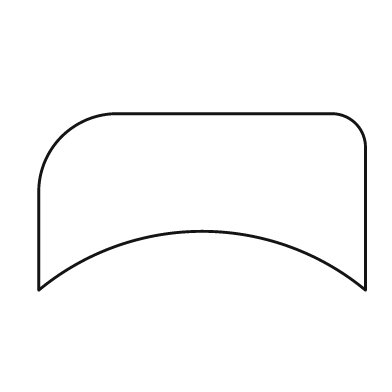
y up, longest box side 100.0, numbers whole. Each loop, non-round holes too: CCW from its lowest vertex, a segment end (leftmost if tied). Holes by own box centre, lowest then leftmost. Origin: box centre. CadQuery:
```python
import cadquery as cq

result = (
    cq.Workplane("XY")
    .moveTo(-50.0, -27.0)
    .threePointArc((0.0, -9.0), (50.0, -27.0))
    .lineTo(50.0, 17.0)
    .threePointArc((47.0, 24.0), (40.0, 27.0))
    .lineTo(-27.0, 27.0)
    .threePointArc((-43.0, 20.0), (-50.0, 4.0))
    .close()
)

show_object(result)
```